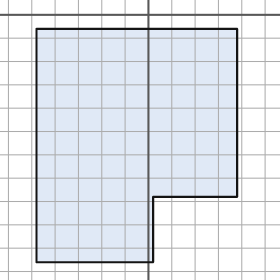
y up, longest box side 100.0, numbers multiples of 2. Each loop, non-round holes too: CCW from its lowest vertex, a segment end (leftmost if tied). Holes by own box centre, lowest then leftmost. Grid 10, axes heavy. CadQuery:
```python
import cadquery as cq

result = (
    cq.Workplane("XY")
    .moveTo(-48.0, -106.0)
    .lineTo(2.0, -106.0)
    .lineTo(2.0, -78.0)
    .lineTo(38.0, -78.0)
    .lineTo(38.0, -6.0)
    .lineTo(-48.0, -6.0)
    .close()
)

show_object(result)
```